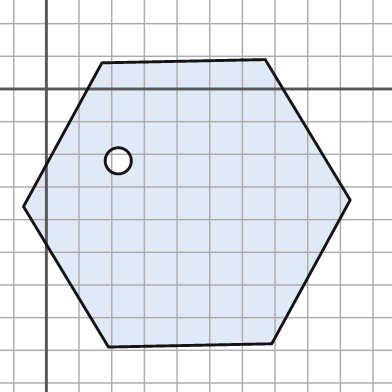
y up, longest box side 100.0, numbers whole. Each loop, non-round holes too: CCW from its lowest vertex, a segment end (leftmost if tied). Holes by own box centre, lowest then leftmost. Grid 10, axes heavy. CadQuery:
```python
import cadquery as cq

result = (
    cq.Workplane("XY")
    .moveTo(19.0, -79.0)
    .lineTo(69.0, -78.0)
    .lineTo(93.0, -34.0)
    .lineTo(67.0, 9.0)
    .lineTo(17.0, 8.0)
    .lineTo(-7.0, -36.0)
    .close()
    .moveTo(22.0, -22.0)
    .circle(4.0)
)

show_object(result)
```